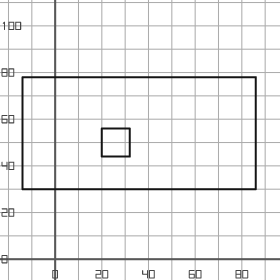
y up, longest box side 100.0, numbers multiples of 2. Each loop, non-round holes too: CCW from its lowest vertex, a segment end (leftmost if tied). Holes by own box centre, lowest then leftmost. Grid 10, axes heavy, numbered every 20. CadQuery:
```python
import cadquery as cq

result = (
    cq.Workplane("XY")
    .moveTo(-14.0, 30.0)
    .lineTo(86.0, 30.0)
    .lineTo(86.0, 78.0)
    .lineTo(-14.0, 78.0)
    .close()
    .moveTo(20.0, 44.0)
    .lineTo(32.0, 44.0)
    .lineTo(32.0, 56.0)
    .lineTo(20.0, 56.0)
    .close()
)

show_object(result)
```